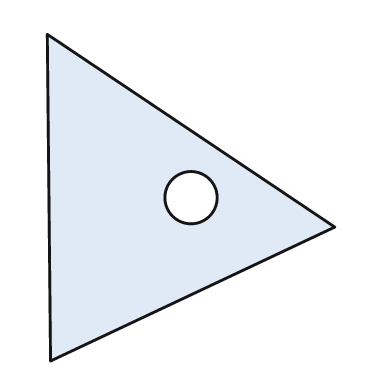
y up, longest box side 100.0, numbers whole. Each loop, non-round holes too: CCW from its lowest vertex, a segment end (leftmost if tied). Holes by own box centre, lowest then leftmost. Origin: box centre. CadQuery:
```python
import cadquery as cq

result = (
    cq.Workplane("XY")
    .moveTo(-43.0, -50.0)
    .lineTo(44.0, -9.0)
    .lineTo(-44.0, 50.0)
    .close()
    .moveTo(0.0, 0.0)
    .circle(8.0)
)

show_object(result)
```